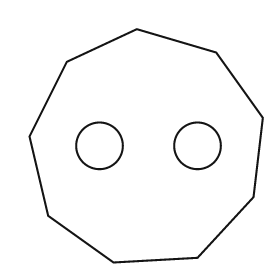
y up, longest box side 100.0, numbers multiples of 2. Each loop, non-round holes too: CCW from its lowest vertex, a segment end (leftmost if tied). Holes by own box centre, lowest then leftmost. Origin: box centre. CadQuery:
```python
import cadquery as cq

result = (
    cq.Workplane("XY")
    .moveTo(-14.0, -50.0)
    .lineTo(22.0, -48.0)
    .lineTo(46.0, -22.0)
    .lineTo(50.0, 12.0)
    .lineTo(30.0, 40.0)
    .lineTo(-4.0, 50.0)
    .lineTo(-34.0, 36.0)
    .lineTo(-50.0, 4.0)
    .lineTo(-42.0, -30.0)
    .close()
    .moveTo(-20.0, 0.0)
    .circle(10.0)
    .moveTo(22.0, 0.0)
    .circle(10.0)
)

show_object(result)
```